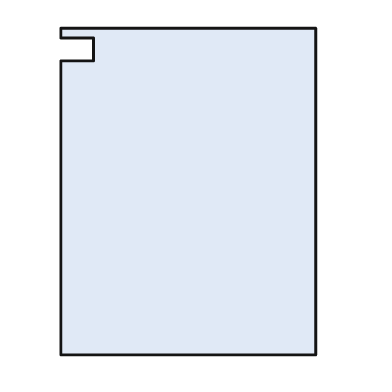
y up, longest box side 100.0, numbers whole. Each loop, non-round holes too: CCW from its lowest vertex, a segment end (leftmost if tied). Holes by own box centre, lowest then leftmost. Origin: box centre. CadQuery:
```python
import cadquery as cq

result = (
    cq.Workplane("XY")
    .moveTo(-39.0, -50.0)
    .lineTo(39.0, -50.0)
    .lineTo(39.0, 50.0)
    .lineTo(-39.0, 50.0)
    .lineTo(-39.0, 47.0)
    .lineTo(-29.0, 47.0)
    .lineTo(-29.0, 40.0)
    .lineTo(-39.0, 40.0)
    .close()
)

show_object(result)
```